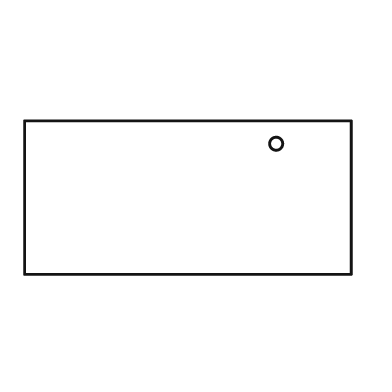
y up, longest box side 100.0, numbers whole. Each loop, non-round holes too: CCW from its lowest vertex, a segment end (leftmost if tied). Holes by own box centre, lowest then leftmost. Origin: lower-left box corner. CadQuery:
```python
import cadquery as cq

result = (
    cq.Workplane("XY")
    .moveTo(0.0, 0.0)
    .lineTo(100.0, 0.0)
    .lineTo(100.0, 47.0)
    .lineTo(0.0, 47.0)
    .close()
    .moveTo(77.0, 40.0)
    .circle(2.0)
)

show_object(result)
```